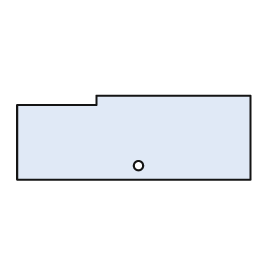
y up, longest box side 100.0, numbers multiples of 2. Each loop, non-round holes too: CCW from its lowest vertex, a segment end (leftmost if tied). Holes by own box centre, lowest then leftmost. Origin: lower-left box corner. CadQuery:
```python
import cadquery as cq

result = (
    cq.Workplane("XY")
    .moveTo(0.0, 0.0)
    .lineTo(100.0, 0.0)
    .lineTo(100.0, 36.0)
    .lineTo(34.0, 36.0)
    .lineTo(34.0, 32.0)
    .lineTo(0.0, 32.0)
    .close()
    .moveTo(52.0, 6.0)
    .circle(2.0)
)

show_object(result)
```